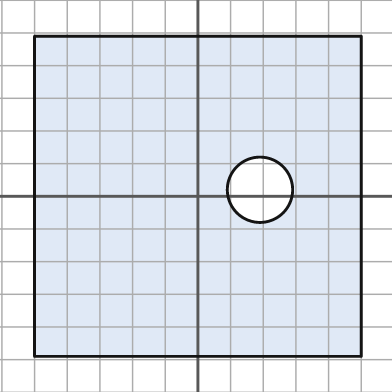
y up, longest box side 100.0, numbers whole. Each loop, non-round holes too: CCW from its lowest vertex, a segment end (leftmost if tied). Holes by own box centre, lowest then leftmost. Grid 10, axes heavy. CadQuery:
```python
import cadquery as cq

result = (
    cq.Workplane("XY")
    .moveTo(-50.0, -49.0)
    .lineTo(50.0, -49.0)
    .lineTo(50.0, 49.0)
    .lineTo(-50.0, 49.0)
    .close()
    .moveTo(19.0, 2.0)
    .circle(10.0)
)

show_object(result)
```